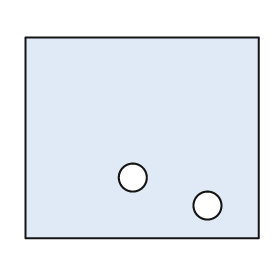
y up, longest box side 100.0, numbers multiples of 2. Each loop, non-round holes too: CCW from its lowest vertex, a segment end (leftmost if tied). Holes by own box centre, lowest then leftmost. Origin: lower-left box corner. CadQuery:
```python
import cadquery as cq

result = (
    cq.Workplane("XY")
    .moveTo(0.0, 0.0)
    .lineTo(100.0, 0.0)
    .lineTo(100.0, 86.0)
    .lineTo(0.0, 86.0)
    .close()
    .moveTo(78.0, 14.0)
    .circle(6.0)
    .moveTo(46.0, 26.0)
    .circle(6.0)
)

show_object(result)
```